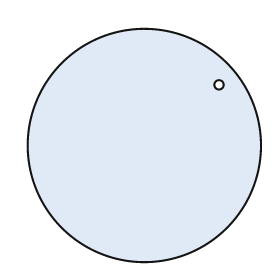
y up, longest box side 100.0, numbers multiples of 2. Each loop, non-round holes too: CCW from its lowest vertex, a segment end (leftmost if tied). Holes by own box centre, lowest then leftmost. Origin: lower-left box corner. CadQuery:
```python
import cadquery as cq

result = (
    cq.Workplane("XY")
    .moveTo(50.0, 50.0)
    .circle(50.0)
    .moveTo(82.0, 76.0)
    .circle(2.0)
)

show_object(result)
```